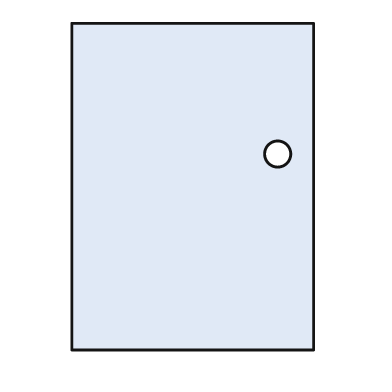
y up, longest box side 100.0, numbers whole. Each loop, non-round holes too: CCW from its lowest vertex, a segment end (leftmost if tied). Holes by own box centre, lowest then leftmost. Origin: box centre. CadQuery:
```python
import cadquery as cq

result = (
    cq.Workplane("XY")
    .moveTo(-37.0, -50.0)
    .lineTo(37.0, -50.0)
    .lineTo(37.0, 50.0)
    .lineTo(-37.0, 50.0)
    .close()
    .moveTo(26.0, 10.0)
    .circle(4.0)
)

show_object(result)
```